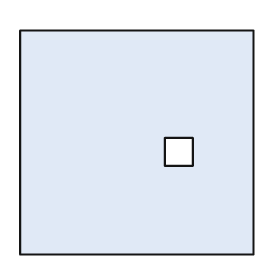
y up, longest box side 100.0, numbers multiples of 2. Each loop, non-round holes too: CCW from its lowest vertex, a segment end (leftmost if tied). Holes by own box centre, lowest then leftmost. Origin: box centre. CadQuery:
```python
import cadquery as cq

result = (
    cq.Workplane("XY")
    .moveTo(-50.0, -48.0)
    .lineTo(50.0, -48.0)
    .lineTo(50.0, 48.0)
    .lineTo(-50.0, 48.0)
    .close()
    .moveTo(12.0, -10.0)
    .lineTo(24.0, -10.0)
    .lineTo(24.0, 2.0)
    .lineTo(12.0, 2.0)
    .close()
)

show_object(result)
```